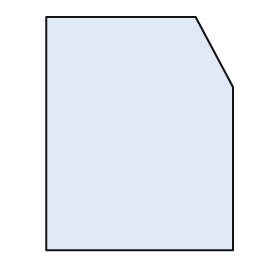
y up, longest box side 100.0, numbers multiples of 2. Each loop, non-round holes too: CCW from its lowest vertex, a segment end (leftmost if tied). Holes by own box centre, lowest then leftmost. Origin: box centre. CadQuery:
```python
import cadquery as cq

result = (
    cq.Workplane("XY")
    .moveTo(-40.0, -50.0)
    .lineTo(40.0, -50.0)
    .lineTo(40.0, 20.0)
    .lineTo(24.0, 50.0)
    .lineTo(-40.0, 50.0)
    .close()
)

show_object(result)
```